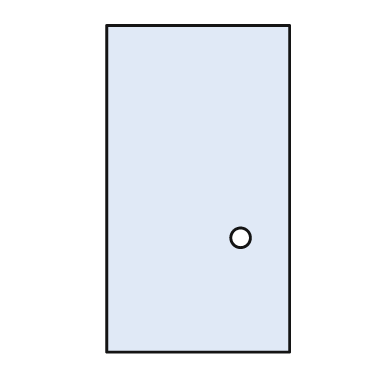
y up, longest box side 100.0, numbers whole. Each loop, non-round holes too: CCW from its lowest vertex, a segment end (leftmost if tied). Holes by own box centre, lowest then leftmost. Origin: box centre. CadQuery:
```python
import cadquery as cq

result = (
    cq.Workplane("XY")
    .moveTo(-28.0, -50.0)
    .lineTo(28.0, -50.0)
    .lineTo(28.0, 50.0)
    .lineTo(-28.0, 50.0)
    .close()
    .moveTo(13.0, -15.0)
    .circle(3.0)
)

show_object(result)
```